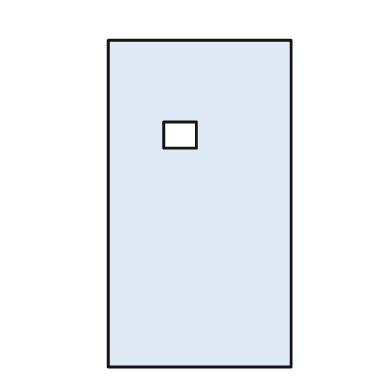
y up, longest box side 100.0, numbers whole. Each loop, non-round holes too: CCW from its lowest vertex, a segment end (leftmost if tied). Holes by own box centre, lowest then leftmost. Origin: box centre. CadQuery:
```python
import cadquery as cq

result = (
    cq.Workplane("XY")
    .moveTo(-28.0, -50.0)
    .lineTo(28.0, -50.0)
    .lineTo(28.0, 50.0)
    .lineTo(-28.0, 50.0)
    .close()
    .moveTo(-11.0, 17.0)
    .lineTo(-1.0, 17.0)
    .lineTo(-1.0, 25.0)
    .lineTo(-11.0, 25.0)
    .close()
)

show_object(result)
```